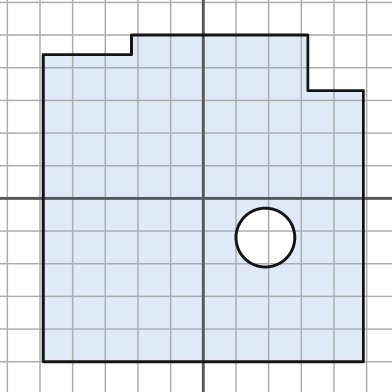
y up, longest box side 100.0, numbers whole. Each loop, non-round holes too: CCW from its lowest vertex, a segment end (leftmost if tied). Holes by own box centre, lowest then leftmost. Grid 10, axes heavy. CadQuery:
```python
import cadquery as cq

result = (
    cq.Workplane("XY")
    .moveTo(-49.0, -50.0)
    .lineTo(49.0, -50.0)
    .lineTo(49.0, 33.0)
    .lineTo(32.0, 33.0)
    .lineTo(32.0, 50.0)
    .lineTo(-22.0, 50.0)
    .lineTo(-22.0, 44.0)
    .lineTo(-49.0, 44.0)
    .close()
    .moveTo(19.0, -12.0)
    .circle(9.0)
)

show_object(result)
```